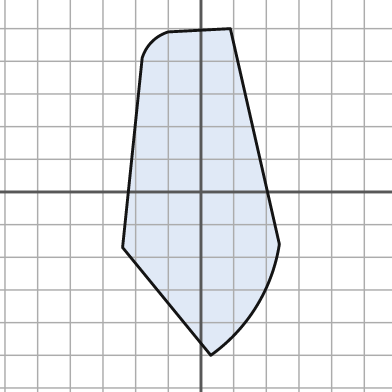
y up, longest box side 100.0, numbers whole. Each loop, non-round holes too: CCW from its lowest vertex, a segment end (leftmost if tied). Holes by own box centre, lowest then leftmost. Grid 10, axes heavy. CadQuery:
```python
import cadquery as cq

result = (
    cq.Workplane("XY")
    .moveTo(3.0, -50.0)
    .threePointArc((17.0, -35.0), (24.0, -16.0))
    .lineTo(9.0, 50.0)
    .lineTo(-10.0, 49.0)
    .threePointArc((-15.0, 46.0), (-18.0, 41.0))
    .lineTo(-24.0, -17.0)
    .close()
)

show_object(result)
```